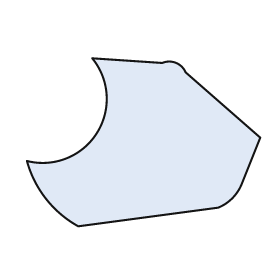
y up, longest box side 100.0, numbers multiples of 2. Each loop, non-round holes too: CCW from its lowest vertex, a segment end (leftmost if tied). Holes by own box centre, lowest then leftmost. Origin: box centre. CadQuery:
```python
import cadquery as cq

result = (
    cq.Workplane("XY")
    .moveTo(-28.0, -36.0)
    .lineTo(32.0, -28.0)
    .threePointArc((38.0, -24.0), (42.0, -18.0))
    .lineTo(50.0, 2.0)
    .lineTo(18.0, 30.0)
    .threePointArc((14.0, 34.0), (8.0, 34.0))
    .lineTo(-22.0, 36.0)
    .threePointArc((-20.0, 4.0), (-50.0, -8.0))
    .threePointArc((-42.0, -24.0), (-28.0, -36.0))
    .close()
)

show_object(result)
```